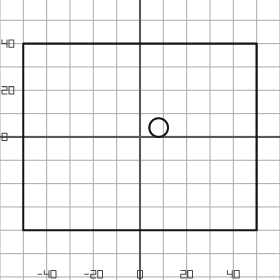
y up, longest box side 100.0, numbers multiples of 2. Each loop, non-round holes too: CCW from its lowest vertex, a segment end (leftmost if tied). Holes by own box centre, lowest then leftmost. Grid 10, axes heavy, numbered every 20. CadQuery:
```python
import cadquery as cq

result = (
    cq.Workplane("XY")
    .moveTo(-50.0, -40.0)
    .lineTo(50.0, -40.0)
    .lineTo(50.0, 40.0)
    .lineTo(-50.0, 40.0)
    .close()
    .moveTo(8.0, 4.0)
    .circle(4.0)
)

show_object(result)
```